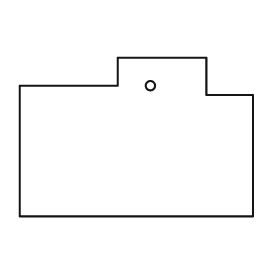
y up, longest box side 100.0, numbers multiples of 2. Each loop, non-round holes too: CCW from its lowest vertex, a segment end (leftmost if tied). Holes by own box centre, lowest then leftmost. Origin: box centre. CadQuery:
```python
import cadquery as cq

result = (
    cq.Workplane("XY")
    .moveTo(-50.0, -34.0)
    .lineTo(50.0, -34.0)
    .lineTo(50.0, 18.0)
    .lineTo(30.0, 18.0)
    .lineTo(30.0, 34.0)
    .lineTo(-8.0, 34.0)
    .lineTo(-8.0, 22.0)
    .lineTo(-50.0, 22.0)
    .close()
    .moveTo(6.0, 22.0)
    .circle(2.0)
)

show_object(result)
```